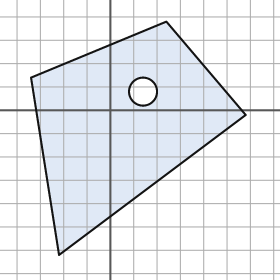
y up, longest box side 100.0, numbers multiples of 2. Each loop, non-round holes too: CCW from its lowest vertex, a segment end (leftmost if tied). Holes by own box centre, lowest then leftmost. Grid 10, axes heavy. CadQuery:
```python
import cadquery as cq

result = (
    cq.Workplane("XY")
    .moveTo(-22.0, -62.0)
    .lineTo(58.0, -2.0)
    .lineTo(24.0, 38.0)
    .lineTo(-34.0, 14.0)
    .close()
    .moveTo(14.0, 8.0)
    .circle(6.0)
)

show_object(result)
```